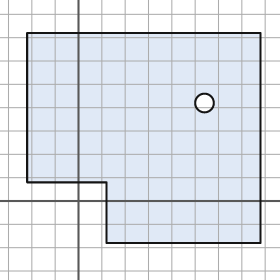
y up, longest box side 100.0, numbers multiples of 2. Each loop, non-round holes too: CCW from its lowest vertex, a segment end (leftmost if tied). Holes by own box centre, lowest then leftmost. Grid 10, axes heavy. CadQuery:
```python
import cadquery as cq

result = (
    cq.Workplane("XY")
    .moveTo(12.0, -18.0)
    .lineTo(78.0, -18.0)
    .lineTo(78.0, 72.0)
    .lineTo(-22.0, 72.0)
    .lineTo(-22.0, 8.0)
    .lineTo(12.0, 8.0)
    .close()
    .moveTo(54.0, 42.0)
    .circle(4.0)
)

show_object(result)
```